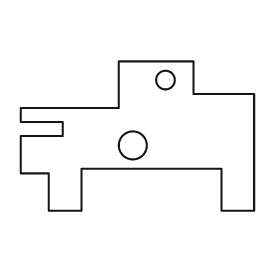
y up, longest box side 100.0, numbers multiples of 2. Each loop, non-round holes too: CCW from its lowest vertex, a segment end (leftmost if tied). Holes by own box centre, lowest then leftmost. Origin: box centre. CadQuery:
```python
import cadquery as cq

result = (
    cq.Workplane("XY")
    .moveTo(-38.0, -32.0)
    .lineTo(-24.0, -32.0)
    .lineTo(-24.0, -14.0)
    .lineTo(36.0, -14.0)
    .lineTo(36.0, -32.0)
    .lineTo(50.0, -32.0)
    .lineTo(50.0, 18.0)
    .lineTo(24.0, 18.0)
    .lineTo(24.0, 32.0)
    .lineTo(-8.0, 32.0)
    .lineTo(-8.0, 12.0)
    .lineTo(-50.0, 12.0)
    .lineTo(-50.0, 6.0)
    .lineTo(-32.0, 6.0)
    .lineTo(-32.0, 0.0)
    .lineTo(-50.0, 0.0)
    .lineTo(-50.0, -16.0)
    .lineTo(-38.0, -16.0)
    .close()
    .moveTo(-2.0, -4.0)
    .circle(6.0)
    .moveTo(12.0, 24.0)
    .circle(4.0)
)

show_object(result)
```